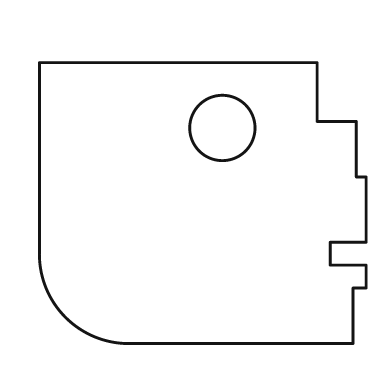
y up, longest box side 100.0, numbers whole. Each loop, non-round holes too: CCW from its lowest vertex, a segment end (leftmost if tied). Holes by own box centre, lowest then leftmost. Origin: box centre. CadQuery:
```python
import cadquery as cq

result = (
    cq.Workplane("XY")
    .moveTo(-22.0, -43.0)
    .lineTo(46.0, -43.0)
    .lineTo(46.0, -26.0)
    .lineTo(50.0, -26.0)
    .lineTo(50.0, -19.0)
    .lineTo(39.0, -19.0)
    .lineTo(39.0, -12.0)
    .lineTo(50.0, -12.0)
    .lineTo(50.0, 8.0)
    .lineTo(47.0, 8.0)
    .lineTo(47.0, 25.0)
    .lineTo(35.0, 25.0)
    .lineTo(35.0, 43.0)
    .lineTo(-50.0, 43.0)
    .lineTo(-50.0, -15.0)
    .threePointArc((-42.0, -35.0), (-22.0, -43.0))
    .close()
    .moveTo(6.0, 23.0)
    .circle(10.0)
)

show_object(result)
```